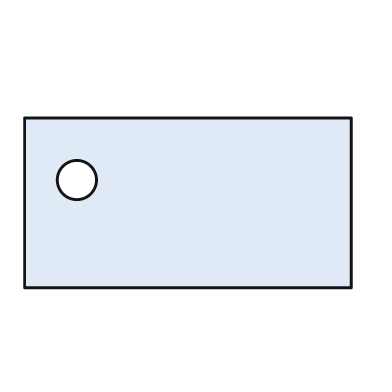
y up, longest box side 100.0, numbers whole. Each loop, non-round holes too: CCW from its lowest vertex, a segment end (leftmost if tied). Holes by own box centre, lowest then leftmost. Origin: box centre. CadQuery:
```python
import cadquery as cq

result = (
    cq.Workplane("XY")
    .moveTo(-50.0, -26.0)
    .lineTo(50.0, -26.0)
    .lineTo(50.0, 26.0)
    .lineTo(-50.0, 26.0)
    .close()
    .moveTo(-34.0, 7.0)
    .circle(6.0)
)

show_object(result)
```